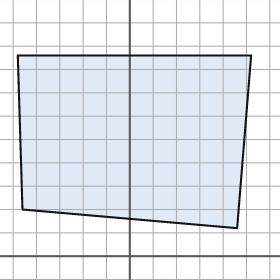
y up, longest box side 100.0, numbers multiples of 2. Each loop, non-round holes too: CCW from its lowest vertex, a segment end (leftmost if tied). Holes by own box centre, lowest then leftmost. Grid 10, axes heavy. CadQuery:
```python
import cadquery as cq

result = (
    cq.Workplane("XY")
    .moveTo(46.0, 12.0)
    .lineTo(52.0, 86.0)
    .lineTo(-48.0, 86.0)
    .lineTo(-46.0, 20.0)
    .close()
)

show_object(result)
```